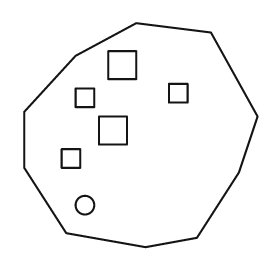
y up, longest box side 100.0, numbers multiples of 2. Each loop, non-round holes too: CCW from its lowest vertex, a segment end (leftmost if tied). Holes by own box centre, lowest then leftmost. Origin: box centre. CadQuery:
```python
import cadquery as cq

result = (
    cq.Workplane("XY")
    .moveTo(2.0, -48.0)
    .lineTo(24.0, -44.0)
    .lineTo(42.0, -16.0)
    .lineTo(50.0, 8.0)
    .lineTo(30.0, 44.0)
    .lineTo(-2.0, 48.0)
    .lineTo(-28.0, 34.0)
    .lineTo(-50.0, 10.0)
    .lineTo(-50.0, -14.0)
    .lineTo(-32.0, -42.0)
    .close()
    .moveTo(-24.0, -30.0)
    .circle(4.0)
    .moveTo(-34.0, -14.0)
    .lineTo(-26.0, -14.0)
    .lineTo(-26.0, -6.0)
    .lineTo(-34.0, -6.0)
    .close()
    .moveTo(-18.0, -4.0)
    .lineTo(-6.0, -4.0)
    .lineTo(-6.0, 8.0)
    .lineTo(-18.0, 8.0)
    .close()
    .moveTo(-28.0, 12.0)
    .lineTo(-20.0, 12.0)
    .lineTo(-20.0, 20.0)
    .lineTo(-28.0, 20.0)
    .close()
    .moveTo(12.0, 14.0)
    .lineTo(20.0, 14.0)
    .lineTo(20.0, 22.0)
    .lineTo(12.0, 22.0)
    .close()
    .moveTo(-14.0, 24.0)
    .lineTo(-2.0, 24.0)
    .lineTo(-2.0, 36.0)
    .lineTo(-14.0, 36.0)
    .close()
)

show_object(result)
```